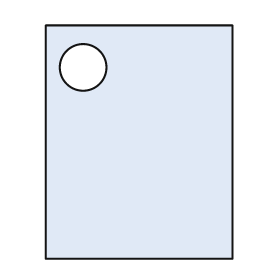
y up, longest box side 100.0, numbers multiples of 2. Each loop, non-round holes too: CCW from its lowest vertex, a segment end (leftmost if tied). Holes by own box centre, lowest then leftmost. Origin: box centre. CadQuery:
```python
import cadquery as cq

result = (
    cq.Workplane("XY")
    .moveTo(-40.0, -50.0)
    .lineTo(40.0, -50.0)
    .lineTo(40.0, 50.0)
    .lineTo(-40.0, 50.0)
    .close()
    .moveTo(-24.0, 32.0)
    .circle(10.0)
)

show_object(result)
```